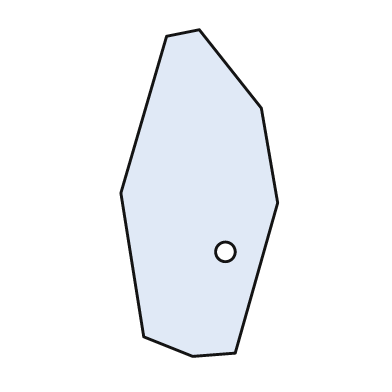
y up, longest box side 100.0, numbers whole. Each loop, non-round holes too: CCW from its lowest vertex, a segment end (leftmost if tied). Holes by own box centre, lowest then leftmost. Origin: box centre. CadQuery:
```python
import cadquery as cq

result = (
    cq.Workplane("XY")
    .moveTo(-2.0, -50.0)
    .lineTo(11.0, -49.0)
    .lineTo(24.0, -3.0)
    .lineTo(19.0, 26.0)
    .lineTo(0.0, 50.0)
    .lineTo(-10.0, 48.0)
    .lineTo(-24.0, 0.0)
    .lineTo(-17.0, -44.0)
    .close()
    .moveTo(8.0, -18.0)
    .circle(3.0)
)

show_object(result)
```